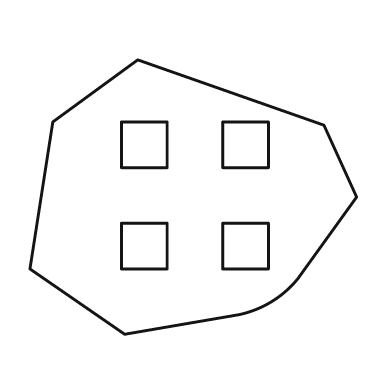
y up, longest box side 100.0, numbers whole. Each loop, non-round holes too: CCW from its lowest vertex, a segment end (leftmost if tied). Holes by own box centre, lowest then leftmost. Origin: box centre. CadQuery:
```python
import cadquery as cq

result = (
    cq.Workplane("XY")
    .moveTo(-21.0, -42.0)
    .lineTo(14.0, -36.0)
    .threePointArc((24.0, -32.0), (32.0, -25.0))
    .lineTo(50.0, 0.0)
    .lineTo(40.0, 22.0)
    .lineTo(-17.0, 42.0)
    .lineTo(-43.0, 23.0)
    .lineTo(-50.0, -22.0)
    .close()
    .moveTo(-22.0, -22.0)
    .lineTo(-8.0, -22.0)
    .lineTo(-8.0, -8.0)
    .lineTo(-22.0, -8.0)
    .close()
    .moveTo(9.0, -22.0)
    .lineTo(23.0, -22.0)
    .lineTo(23.0, -8.0)
    .lineTo(9.0, -8.0)
    .close()
    .moveTo(-22.0, 9.0)
    .lineTo(-8.0, 9.0)
    .lineTo(-8.0, 23.0)
    .lineTo(-22.0, 23.0)
    .close()
    .moveTo(9.0, 9.0)
    .lineTo(23.0, 9.0)
    .lineTo(23.0, 23.0)
    .lineTo(9.0, 23.0)
    .close()
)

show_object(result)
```